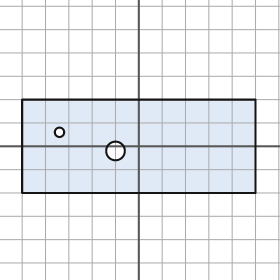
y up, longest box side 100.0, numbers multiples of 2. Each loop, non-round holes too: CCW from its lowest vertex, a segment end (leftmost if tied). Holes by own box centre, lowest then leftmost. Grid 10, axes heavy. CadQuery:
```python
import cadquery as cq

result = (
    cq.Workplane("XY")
    .moveTo(-50.0, -20.0)
    .lineTo(50.0, -20.0)
    .lineTo(50.0, 20.0)
    .lineTo(-50.0, 20.0)
    .close()
    .moveTo(-10.0, -2.0)
    .circle(4.0)
    .moveTo(-34.0, 6.0)
    .circle(2.0)
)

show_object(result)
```